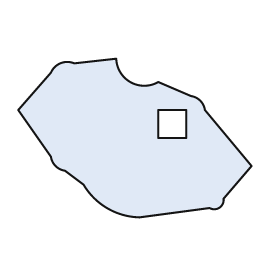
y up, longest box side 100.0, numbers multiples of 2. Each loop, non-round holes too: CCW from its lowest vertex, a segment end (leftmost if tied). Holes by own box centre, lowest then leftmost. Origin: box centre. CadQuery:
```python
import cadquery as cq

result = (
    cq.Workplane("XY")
    .moveTo(2.0, -34.0)
    .lineTo(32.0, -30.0)
    .threePointArc((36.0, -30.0), (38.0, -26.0))
    .lineTo(50.0, -12.0)
    .lineTo(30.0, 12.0)
    .threePointArc((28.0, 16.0), (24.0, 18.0))
    .lineTo(10.0, 24.0)
    .threePointArc((-2.0, 24.0), (-8.0, 34.0))
    .lineTo(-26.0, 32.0)
    .threePointArc((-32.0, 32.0), (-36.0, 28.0))
    .lineTo(-50.0, 12.0)
    .lineTo(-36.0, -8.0)
    .threePointArc((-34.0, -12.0), (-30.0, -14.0))
    .lineTo(-22.0, -20.0)
    .threePointArc((-12.0, -30.0), (2.0, -34.0))
    .close()
    .moveTo(10.0, 0.0)
    .lineTo(22.0, 0.0)
    .lineTo(22.0, 12.0)
    .lineTo(10.0, 12.0)
    .close()
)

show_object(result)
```